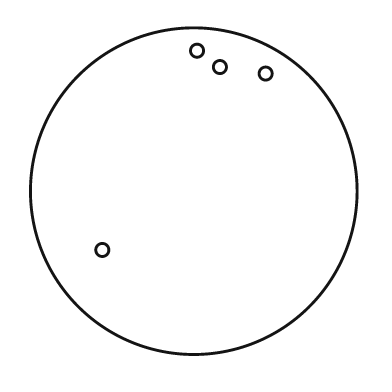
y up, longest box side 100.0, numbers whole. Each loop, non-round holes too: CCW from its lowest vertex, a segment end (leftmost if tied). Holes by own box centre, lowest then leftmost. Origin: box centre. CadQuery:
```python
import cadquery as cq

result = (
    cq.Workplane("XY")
    .moveTo(0.0, 0.0)
    .circle(50.0)
    .moveTo(-28.0, -18.0)
    .circle(2.0)
    .moveTo(22.0, 36.0)
    .circle(2.0)
    .moveTo(8.0, 38.0)
    .circle(2.0)
    .moveTo(1.0, 43.0)
    .circle(2.0)
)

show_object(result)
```